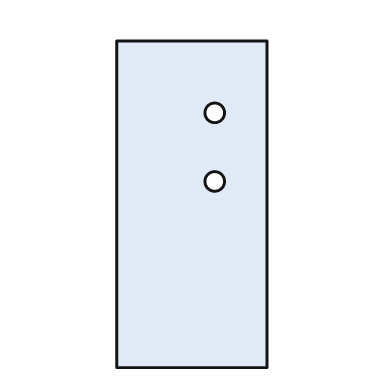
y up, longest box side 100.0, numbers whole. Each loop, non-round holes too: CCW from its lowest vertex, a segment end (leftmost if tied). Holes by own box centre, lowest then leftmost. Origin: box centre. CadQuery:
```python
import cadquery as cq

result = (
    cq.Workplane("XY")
    .moveTo(-23.0, -50.0)
    .lineTo(23.0, -50.0)
    .lineTo(23.0, 50.0)
    .lineTo(-23.0, 50.0)
    .close()
    .moveTo(7.0, 7.0)
    .circle(3.0)
    .moveTo(7.0, 28.0)
    .circle(3.0)
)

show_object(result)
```